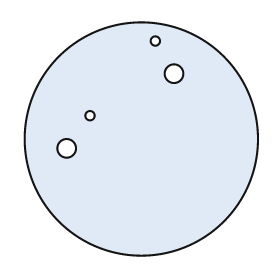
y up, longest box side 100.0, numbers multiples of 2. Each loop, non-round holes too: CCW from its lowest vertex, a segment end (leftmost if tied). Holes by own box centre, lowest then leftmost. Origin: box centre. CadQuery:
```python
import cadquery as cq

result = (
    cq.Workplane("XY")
    .moveTo(0.0, 0.0)
    .circle(50.0)
    .moveTo(-32.0, -4.0)
    .circle(4.0)
    .moveTo(-22.0, 10.0)
    .circle(2.0)
    .moveTo(14.0, 28.0)
    .circle(4.0)
    .moveTo(6.0, 42.0)
    .circle(2.0)
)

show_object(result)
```